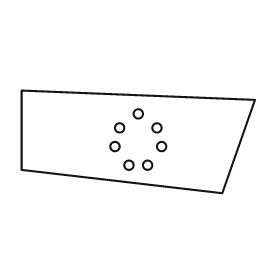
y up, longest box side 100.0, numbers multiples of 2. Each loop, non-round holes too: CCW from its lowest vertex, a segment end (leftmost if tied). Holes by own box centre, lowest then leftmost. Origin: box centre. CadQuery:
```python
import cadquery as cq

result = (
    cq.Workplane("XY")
    .moveTo(36.0, -22.0)
    .lineTo(50.0, 18.0)
    .lineTo(-50.0, 22.0)
    .lineTo(-50.0, -12.0)
    .close()
    .moveTo(-4.0, -10.0)
    .circle(2.0)
    .moveTo(4.0, -10.0)
    .circle(2.0)
    .moveTo(-10.0, -2.0)
    .circle(2.0)
    .moveTo(10.0, -2.0)
    .circle(2.0)
    .moveTo(-8.0, 6.0)
    .circle(2.0)
    .moveTo(8.0, 6.0)
    .circle(2.0)
    .moveTo(0.0, 12.0)
    .circle(2.0)
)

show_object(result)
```